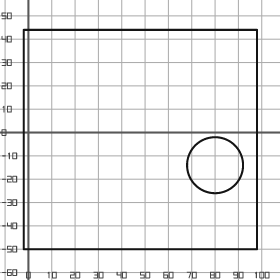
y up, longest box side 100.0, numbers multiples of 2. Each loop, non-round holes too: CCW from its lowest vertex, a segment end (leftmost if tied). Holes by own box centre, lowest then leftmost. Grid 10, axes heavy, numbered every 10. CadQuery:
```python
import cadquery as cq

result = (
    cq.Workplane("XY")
    .moveTo(-2.0, -50.0)
    .lineTo(98.0, -50.0)
    .lineTo(98.0, 44.0)
    .lineTo(-2.0, 44.0)
    .close()
    .moveTo(80.0, -14.0)
    .circle(12.0)
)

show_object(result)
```